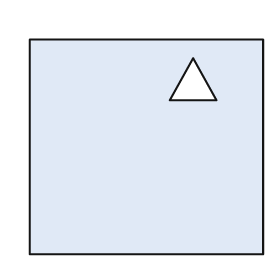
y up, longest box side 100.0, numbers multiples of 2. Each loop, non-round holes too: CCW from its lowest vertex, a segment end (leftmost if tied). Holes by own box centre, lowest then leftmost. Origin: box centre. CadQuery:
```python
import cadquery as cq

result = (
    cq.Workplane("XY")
    .moveTo(-50.0, -46.0)
    .lineTo(50.0, -46.0)
    .lineTo(50.0, 46.0)
    .lineTo(-50.0, 46.0)
    .close()
    .moveTo(10.0, 20.0)
    .lineTo(30.0, 20.0)
    .lineTo(20.0, 38.0)
    .close()
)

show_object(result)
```